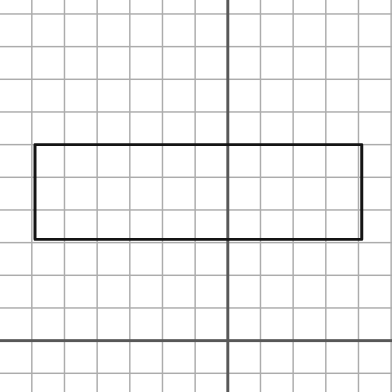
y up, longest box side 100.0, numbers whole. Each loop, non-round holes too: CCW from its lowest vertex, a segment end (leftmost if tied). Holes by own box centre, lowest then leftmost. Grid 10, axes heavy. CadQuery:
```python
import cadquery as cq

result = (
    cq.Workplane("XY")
    .moveTo(-59.0, 31.0)
    .lineTo(41.0, 31.0)
    .lineTo(41.0, 60.0)
    .lineTo(-59.0, 60.0)
    .close()
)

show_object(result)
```